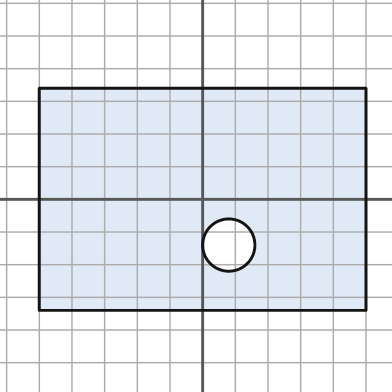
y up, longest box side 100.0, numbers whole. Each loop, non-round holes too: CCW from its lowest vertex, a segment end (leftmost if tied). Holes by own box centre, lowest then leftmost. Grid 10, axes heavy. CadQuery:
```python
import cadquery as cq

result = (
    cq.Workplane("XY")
    .moveTo(-50.0, -34.0)
    .lineTo(50.0, -34.0)
    .lineTo(50.0, 34.0)
    .lineTo(-50.0, 34.0)
    .close()
    .moveTo(8.0, -14.0)
    .circle(8.0)
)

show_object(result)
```